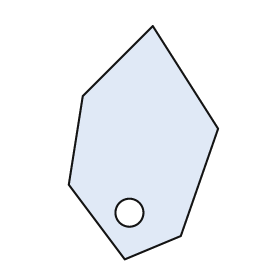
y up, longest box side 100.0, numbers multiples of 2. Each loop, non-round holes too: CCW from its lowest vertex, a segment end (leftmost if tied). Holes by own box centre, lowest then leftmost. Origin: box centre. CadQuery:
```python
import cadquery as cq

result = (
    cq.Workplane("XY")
    .moveTo(-8.0, -50.0)
    .lineTo(16.0, -40.0)
    .lineTo(32.0, 6.0)
    .lineTo(4.0, 50.0)
    .lineTo(-26.0, 20.0)
    .lineTo(-32.0, -18.0)
    .close()
    .moveTo(-6.0, -30.0)
    .circle(6.0)
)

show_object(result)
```